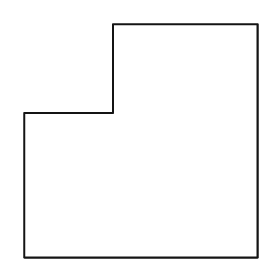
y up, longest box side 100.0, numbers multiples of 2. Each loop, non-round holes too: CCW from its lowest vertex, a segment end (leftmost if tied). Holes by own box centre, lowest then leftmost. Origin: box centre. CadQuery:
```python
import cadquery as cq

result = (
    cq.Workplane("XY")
    .moveTo(-50.0, -50.0)
    .lineTo(50.0, -50.0)
    .lineTo(50.0, 50.0)
    .lineTo(-12.0, 50.0)
    .lineTo(-12.0, 12.0)
    .lineTo(-50.0, 12.0)
    .close()
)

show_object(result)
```